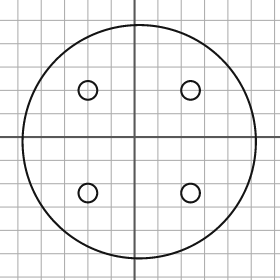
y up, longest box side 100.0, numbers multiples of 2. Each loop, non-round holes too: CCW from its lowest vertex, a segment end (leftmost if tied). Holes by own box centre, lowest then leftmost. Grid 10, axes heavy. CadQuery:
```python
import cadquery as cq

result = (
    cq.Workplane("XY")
    .moveTo(2.0, -2.0)
    .circle(50.0)
    .moveTo(-20.0, -24.0)
    .circle(4.0)
    .moveTo(24.0, -24.0)
    .circle(4.0)
    .moveTo(-20.0, 20.0)
    .circle(4.0)
    .moveTo(24.0, 20.0)
    .circle(4.0)
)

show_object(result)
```